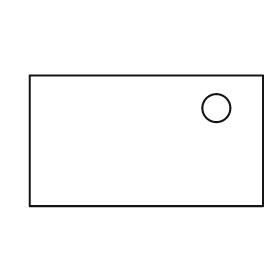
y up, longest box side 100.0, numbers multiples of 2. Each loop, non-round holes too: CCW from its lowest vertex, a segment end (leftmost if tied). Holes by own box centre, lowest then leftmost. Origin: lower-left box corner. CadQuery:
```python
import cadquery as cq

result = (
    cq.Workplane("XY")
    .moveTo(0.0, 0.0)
    .lineTo(100.0, 0.0)
    .lineTo(100.0, 56.0)
    .lineTo(0.0, 56.0)
    .close()
    .moveTo(80.0, 42.0)
    .circle(6.0)
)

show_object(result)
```